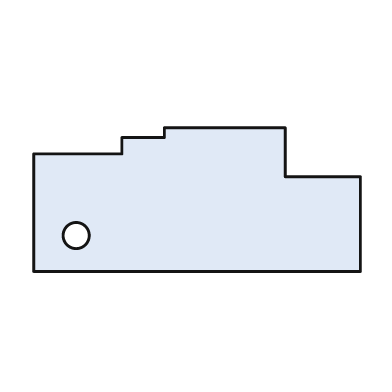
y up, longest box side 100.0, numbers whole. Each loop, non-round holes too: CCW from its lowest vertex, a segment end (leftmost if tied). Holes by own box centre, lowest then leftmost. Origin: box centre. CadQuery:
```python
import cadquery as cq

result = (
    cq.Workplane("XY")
    .moveTo(-50.0, -22.0)
    .lineTo(50.0, -22.0)
    .lineTo(50.0, 7.0)
    .lineTo(27.0, 7.0)
    .lineTo(27.0, 22.0)
    .lineTo(-10.0, 22.0)
    .lineTo(-10.0, 19.0)
    .lineTo(-23.0, 19.0)
    .lineTo(-23.0, 14.0)
    .lineTo(-50.0, 14.0)
    .close()
    .moveTo(-37.0, -11.0)
    .circle(4.0)
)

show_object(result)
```